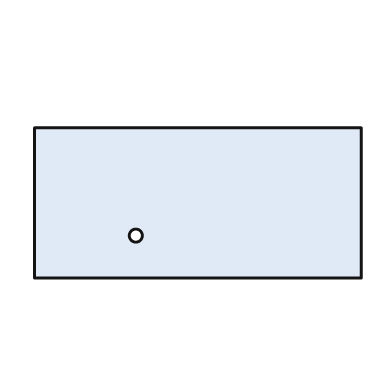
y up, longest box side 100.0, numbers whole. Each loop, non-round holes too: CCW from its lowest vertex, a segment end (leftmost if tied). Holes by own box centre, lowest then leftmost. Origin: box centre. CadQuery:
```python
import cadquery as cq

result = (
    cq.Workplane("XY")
    .moveTo(-50.0, -23.0)
    .lineTo(50.0, -23.0)
    .lineTo(50.0, 23.0)
    .lineTo(-50.0, 23.0)
    .close()
    .moveTo(-19.0, -10.0)
    .circle(2.0)
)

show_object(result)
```